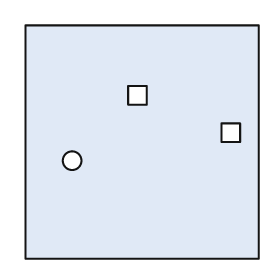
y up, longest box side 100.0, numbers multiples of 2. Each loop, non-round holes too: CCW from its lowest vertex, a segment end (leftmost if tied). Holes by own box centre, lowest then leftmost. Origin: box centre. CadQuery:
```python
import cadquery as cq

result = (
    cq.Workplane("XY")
    .moveTo(-50.0, -50.0)
    .lineTo(50.0, -50.0)
    .lineTo(50.0, 50.0)
    .lineTo(-50.0, 50.0)
    .close()
    .moveTo(-30.0, -8.0)
    .circle(4.0)
    .moveTo(34.0, 0.0)
    .lineTo(42.0, 0.0)
    .lineTo(42.0, 8.0)
    .lineTo(34.0, 8.0)
    .close()
    .moveTo(-6.0, 16.0)
    .lineTo(2.0, 16.0)
    .lineTo(2.0, 24.0)
    .lineTo(-6.0, 24.0)
    .close()
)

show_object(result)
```